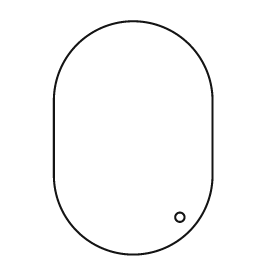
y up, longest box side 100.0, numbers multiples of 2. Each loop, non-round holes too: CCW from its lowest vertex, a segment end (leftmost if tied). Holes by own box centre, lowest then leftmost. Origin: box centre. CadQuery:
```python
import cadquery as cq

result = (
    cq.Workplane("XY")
    .moveTo(-34.0, -16.0)
    .threePointArc((0.0, -50.0), (34.0, -16.0))
    .lineTo(34.0, 16.0)
    .threePointArc((0.0, 50.0), (-34.0, 16.0))
    .close()
    .moveTo(20.0, -34.0)
    .circle(2.0)
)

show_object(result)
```